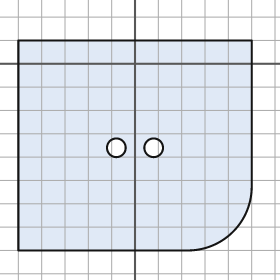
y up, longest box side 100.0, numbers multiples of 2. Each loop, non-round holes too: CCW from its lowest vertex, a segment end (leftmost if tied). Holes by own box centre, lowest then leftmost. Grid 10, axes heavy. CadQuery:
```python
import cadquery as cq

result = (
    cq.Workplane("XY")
    .moveTo(-50.0, -80.0)
    .lineTo(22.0, -80.0)
    .threePointArc((42.0, -72.0), (50.0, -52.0))
    .lineTo(50.0, 10.0)
    .lineTo(-50.0, 10.0)
    .close()
    .moveTo(-8.0, -36.0)
    .circle(4.0)
    .moveTo(8.0, -36.0)
    .circle(4.0)
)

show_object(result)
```